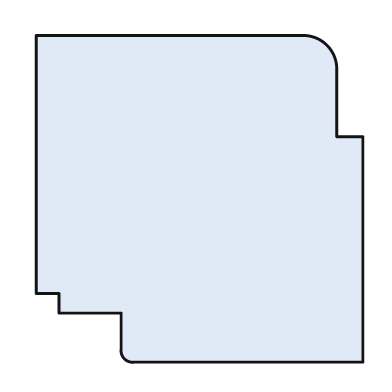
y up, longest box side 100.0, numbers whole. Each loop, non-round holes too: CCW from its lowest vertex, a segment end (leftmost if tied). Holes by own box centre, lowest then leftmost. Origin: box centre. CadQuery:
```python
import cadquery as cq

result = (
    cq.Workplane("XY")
    .moveTo(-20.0, -50.0)
    .lineTo(50.0, -50.0)
    .lineTo(50.0, 19.0)
    .lineTo(42.0, 19.0)
    .lineTo(42.0, 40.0)
    .threePointArc((39.0, 47.0), (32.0, 50.0))
    .lineTo(-50.0, 50.0)
    .lineTo(-50.0, -29.0)
    .lineTo(-43.0, -29.0)
    .lineTo(-43.0, -35.0)
    .lineTo(-24.0, -35.0)
    .lineTo(-24.0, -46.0)
    .threePointArc((-23.0, -49.0), (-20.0, -50.0))
    .close()
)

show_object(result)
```